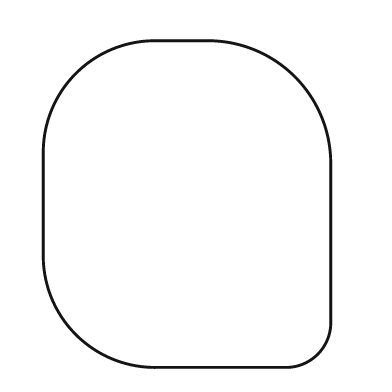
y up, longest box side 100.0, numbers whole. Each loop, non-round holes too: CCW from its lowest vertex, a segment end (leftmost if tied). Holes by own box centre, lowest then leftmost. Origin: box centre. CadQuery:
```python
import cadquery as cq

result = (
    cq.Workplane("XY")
    .moveTo(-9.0, -50.0)
    .lineTo(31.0, -50.0)
    .threePointArc((40.0, -46.0), (44.0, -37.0))
    .lineTo(44.0, 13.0)
    .threePointArc((33.0, 39.0), (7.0, 50.0))
    .lineTo(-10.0, 50.0)
    .threePointArc((-34.0, 40.0), (-44.0, 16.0))
    .lineTo(-44.0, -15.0)
    .threePointArc((-34.0, -40.0), (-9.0, -50.0))
    .close()
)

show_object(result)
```